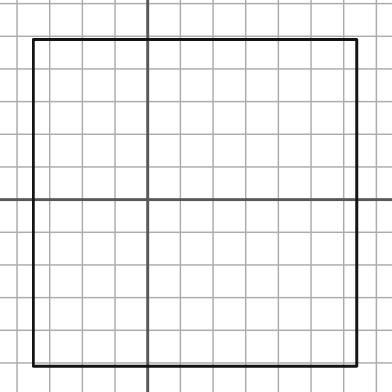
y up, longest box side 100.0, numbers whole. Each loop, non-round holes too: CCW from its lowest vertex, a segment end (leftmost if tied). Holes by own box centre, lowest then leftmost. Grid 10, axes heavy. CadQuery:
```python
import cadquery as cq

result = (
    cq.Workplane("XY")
    .moveTo(-35.0, -51.0)
    .lineTo(64.0, -51.0)
    .lineTo(64.0, 49.0)
    .lineTo(-35.0, 49.0)
    .close()
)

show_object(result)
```